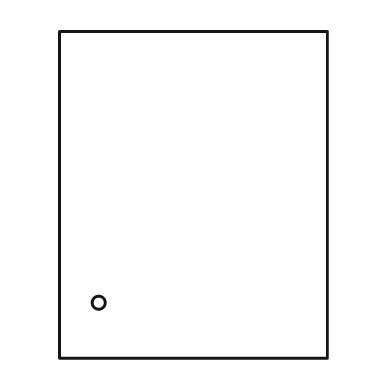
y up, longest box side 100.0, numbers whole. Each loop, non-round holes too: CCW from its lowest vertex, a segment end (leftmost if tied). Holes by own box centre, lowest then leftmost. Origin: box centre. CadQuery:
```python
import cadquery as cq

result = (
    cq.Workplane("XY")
    .moveTo(-41.0, -50.0)
    .lineTo(41.0, -50.0)
    .lineTo(41.0, 50.0)
    .lineTo(-41.0, 50.0)
    .close()
    .moveTo(-29.0, -33.0)
    .circle(2.0)
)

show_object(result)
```